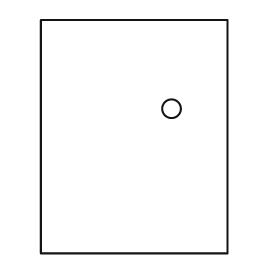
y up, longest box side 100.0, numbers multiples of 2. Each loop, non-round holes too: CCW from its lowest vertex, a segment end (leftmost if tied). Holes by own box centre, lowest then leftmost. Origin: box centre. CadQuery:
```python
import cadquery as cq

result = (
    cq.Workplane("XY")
    .moveTo(-40.0, -50.0)
    .lineTo(40.0, -50.0)
    .lineTo(40.0, 50.0)
    .lineTo(-40.0, 50.0)
    .close()
    .moveTo(16.0, 12.0)
    .circle(4.0)
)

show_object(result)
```